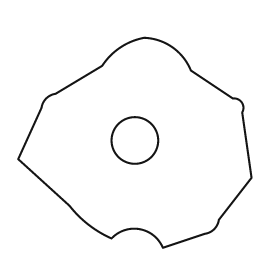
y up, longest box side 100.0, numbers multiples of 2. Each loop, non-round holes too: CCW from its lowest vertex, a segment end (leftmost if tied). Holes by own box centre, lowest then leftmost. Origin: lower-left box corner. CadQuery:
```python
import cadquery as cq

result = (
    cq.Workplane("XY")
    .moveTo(62.0, 0.0)
    .lineTo(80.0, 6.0)
    .threePointArc((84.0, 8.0), (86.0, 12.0))
    .lineTo(100.0, 30.0)
    .lineTo(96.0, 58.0)
    .threePointArc((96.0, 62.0), (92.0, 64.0))
    .lineTo(74.0, 76.0)
    .threePointArc((66.0, 86.0), (54.0, 90.0))
    .threePointArc((44.0, 86.0), (36.0, 78.0))
    .lineTo(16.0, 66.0)
    .threePointArc((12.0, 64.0), (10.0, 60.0))
    .lineTo(0.0, 38.0)
    .lineTo(22.0, 18.0)
    .threePointArc((30.0, 10.0), (40.0, 4.0))
    .threePointArc((52.0, 8.0), (62.0, 0.0))
    .close()
    .moveTo(50.0, 46.0)
    .circle(10.0)
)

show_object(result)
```